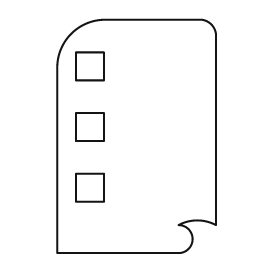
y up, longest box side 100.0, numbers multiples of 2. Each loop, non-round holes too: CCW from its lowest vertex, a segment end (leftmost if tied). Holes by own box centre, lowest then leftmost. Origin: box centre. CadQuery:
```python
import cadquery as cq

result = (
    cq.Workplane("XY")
    .moveTo(-34.0, -50.0)
    .lineTo(18.0, -50.0)
    .threePointArc((24.0, -44.0), (18.0, -38.0))
    .threePointArc((26.0, -36.0), (34.0, -38.0))
    .lineTo(34.0, 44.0)
    .threePointArc((32.0, 48.0), (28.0, 50.0))
    .lineTo(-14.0, 50.0)
    .threePointArc((-28.0, 44.0), (-34.0, 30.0))
    .close()
    .moveTo(-26.0, -28.0)
    .lineTo(-14.0, -28.0)
    .lineTo(-14.0, -16.0)
    .lineTo(-26.0, -16.0)
    .close()
    .moveTo(-26.0, -2.0)
    .lineTo(-14.0, -2.0)
    .lineTo(-14.0, 10.0)
    .lineTo(-26.0, 10.0)
    .close()
    .moveTo(-26.0, 24.0)
    .lineTo(-14.0, 24.0)
    .lineTo(-14.0, 36.0)
    .lineTo(-26.0, 36.0)
    .close()
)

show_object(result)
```